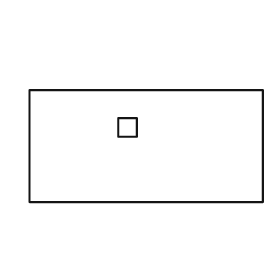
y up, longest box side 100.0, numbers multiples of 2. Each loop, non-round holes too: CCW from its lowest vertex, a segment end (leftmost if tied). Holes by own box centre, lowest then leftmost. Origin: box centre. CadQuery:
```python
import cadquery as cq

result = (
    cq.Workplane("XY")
    .moveTo(-50.0, -24.0)
    .lineTo(50.0, -24.0)
    .lineTo(50.0, 24.0)
    .lineTo(-50.0, 24.0)
    .close()
    .moveTo(-12.0, 4.0)
    .lineTo(-4.0, 4.0)
    .lineTo(-4.0, 12.0)
    .lineTo(-12.0, 12.0)
    .close()
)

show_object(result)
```